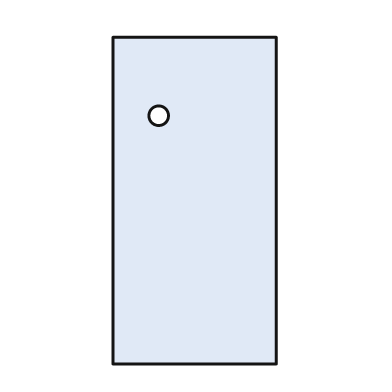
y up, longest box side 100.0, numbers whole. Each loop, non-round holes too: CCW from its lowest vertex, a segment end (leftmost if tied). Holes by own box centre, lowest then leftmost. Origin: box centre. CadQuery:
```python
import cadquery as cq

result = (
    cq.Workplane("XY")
    .moveTo(-25.0, -50.0)
    .lineTo(25.0, -50.0)
    .lineTo(25.0, 50.0)
    .lineTo(-25.0, 50.0)
    .close()
    .moveTo(-11.0, 26.0)
    .circle(3.0)
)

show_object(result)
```